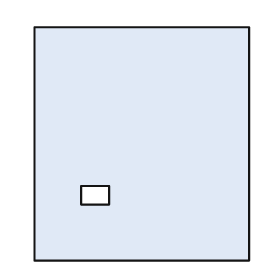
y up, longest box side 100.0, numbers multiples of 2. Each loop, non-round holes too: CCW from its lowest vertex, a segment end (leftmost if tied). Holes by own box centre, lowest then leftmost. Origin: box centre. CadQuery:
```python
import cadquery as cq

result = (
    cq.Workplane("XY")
    .moveTo(-46.0, -50.0)
    .lineTo(46.0, -50.0)
    .lineTo(46.0, 50.0)
    .lineTo(-46.0, 50.0)
    .close()
    .moveTo(-26.0, -26.0)
    .lineTo(-14.0, -26.0)
    .lineTo(-14.0, -18.0)
    .lineTo(-26.0, -18.0)
    .close()
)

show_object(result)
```